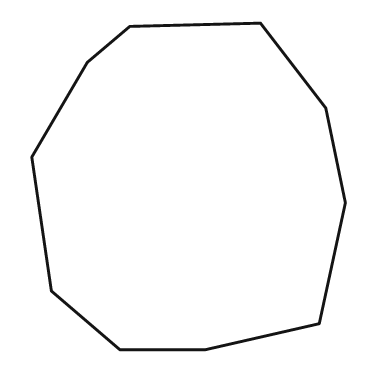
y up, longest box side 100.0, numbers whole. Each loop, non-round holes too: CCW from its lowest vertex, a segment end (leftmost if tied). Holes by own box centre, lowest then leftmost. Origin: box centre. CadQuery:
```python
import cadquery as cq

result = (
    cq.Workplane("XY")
    .moveTo(-21.0, -50.0)
    .lineTo(5.0, -50.0)
    .lineTo(40.0, -42.0)
    .lineTo(48.0, -5.0)
    .lineTo(42.0, 24.0)
    .lineTo(22.0, 50.0)
    .lineTo(-18.0, 49.0)
    .lineTo(-31.0, 38.0)
    .lineTo(-48.0, 9.0)
    .lineTo(-42.0, -32.0)
    .close()
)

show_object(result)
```